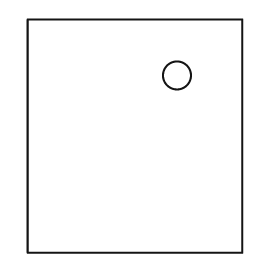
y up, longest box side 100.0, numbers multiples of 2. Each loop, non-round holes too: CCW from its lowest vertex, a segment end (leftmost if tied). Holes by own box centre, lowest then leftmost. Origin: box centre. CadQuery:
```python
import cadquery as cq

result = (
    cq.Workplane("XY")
    .moveTo(-46.0, -50.0)
    .lineTo(46.0, -50.0)
    .lineTo(46.0, 50.0)
    .lineTo(-46.0, 50.0)
    .close()
    .moveTo(18.0, 26.0)
    .circle(6.0)
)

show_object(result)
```